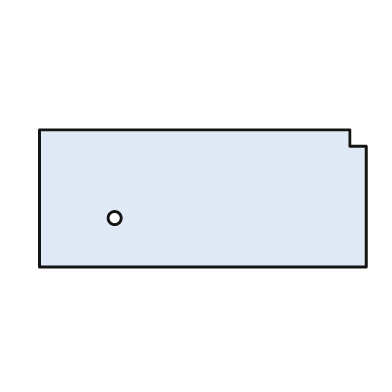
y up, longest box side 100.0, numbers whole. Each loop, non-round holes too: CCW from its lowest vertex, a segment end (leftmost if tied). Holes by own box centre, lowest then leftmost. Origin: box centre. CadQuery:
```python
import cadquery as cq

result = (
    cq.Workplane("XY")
    .moveTo(-50.0, -21.0)
    .lineTo(50.0, -21.0)
    .lineTo(50.0, 16.0)
    .lineTo(45.0, 16.0)
    .lineTo(45.0, 21.0)
    .lineTo(-50.0, 21.0)
    .close()
    .moveTo(-27.0, -6.0)
    .circle(2.0)
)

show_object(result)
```